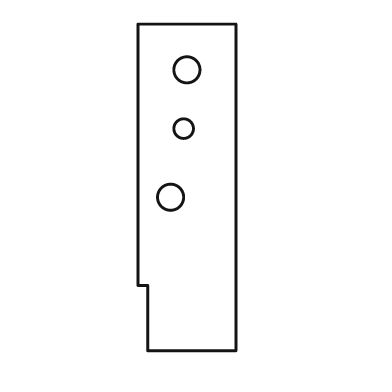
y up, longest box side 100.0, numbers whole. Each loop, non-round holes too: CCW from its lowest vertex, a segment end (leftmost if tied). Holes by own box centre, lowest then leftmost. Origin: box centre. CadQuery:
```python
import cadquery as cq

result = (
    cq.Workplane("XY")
    .moveTo(-12.0, -50.0)
    .lineTo(15.0, -50.0)
    .lineTo(15.0, 50.0)
    .lineTo(-15.0, 50.0)
    .lineTo(-15.0, -30.0)
    .lineTo(-12.0, -30.0)
    .close()
    .moveTo(-5.0, -3.0)
    .circle(4.0)
    .moveTo(-1.0, 18.0)
    .circle(3.0)
    .moveTo(0.0, 36.0)
    .circle(4.0)
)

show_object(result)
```